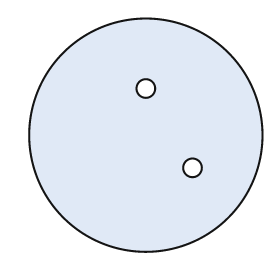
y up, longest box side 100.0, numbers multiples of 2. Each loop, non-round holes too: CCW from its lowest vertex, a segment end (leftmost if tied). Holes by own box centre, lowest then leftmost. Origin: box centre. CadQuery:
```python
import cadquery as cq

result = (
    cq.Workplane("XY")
    .moveTo(0.0, 0.0)
    .circle(50.0)
    .moveTo(20.0, -14.0)
    .circle(4.0)
    .moveTo(0.0, 20.0)
    .circle(4.0)
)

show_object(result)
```